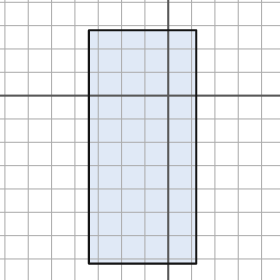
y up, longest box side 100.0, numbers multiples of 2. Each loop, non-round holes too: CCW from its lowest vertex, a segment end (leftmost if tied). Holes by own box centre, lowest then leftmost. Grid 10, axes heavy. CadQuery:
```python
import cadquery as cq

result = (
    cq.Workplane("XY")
    .moveTo(-34.0, -72.0)
    .lineTo(12.0, -72.0)
    .lineTo(12.0, 28.0)
    .lineTo(-34.0, 28.0)
    .close()
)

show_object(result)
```